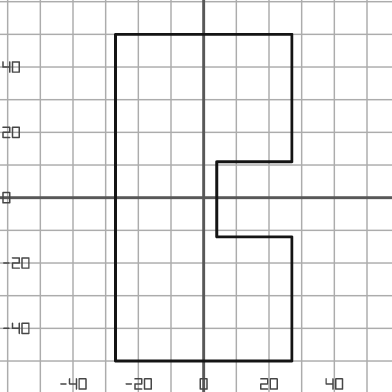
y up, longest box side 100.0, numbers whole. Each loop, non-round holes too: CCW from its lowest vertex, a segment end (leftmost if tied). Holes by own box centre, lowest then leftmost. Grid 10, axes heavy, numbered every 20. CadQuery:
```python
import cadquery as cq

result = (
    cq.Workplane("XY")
    .moveTo(-27.0, -50.0)
    .lineTo(27.0, -50.0)
    .lineTo(27.0, -12.0)
    .lineTo(4.0, -12.0)
    .lineTo(4.0, 11.0)
    .lineTo(27.0, 11.0)
    .lineTo(27.0, 50.0)
    .lineTo(-27.0, 50.0)
    .close()
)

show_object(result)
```